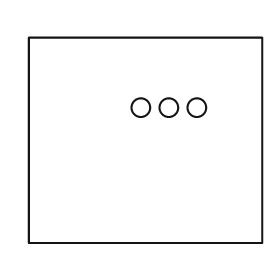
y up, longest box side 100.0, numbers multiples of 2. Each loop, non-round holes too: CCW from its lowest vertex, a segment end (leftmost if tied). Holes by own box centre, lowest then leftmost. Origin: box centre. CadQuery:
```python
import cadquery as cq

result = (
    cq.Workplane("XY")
    .moveTo(-50.0, -44.0)
    .lineTo(50.0, -44.0)
    .lineTo(50.0, 44.0)
    .lineTo(-50.0, 44.0)
    .close()
    .moveTo(-2.0, 14.0)
    .circle(4.0)
    .moveTo(10.0, 14.0)
    .circle(4.0)
    .moveTo(22.0, 14.0)
    .circle(4.0)
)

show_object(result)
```